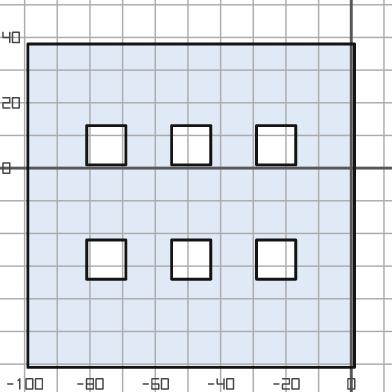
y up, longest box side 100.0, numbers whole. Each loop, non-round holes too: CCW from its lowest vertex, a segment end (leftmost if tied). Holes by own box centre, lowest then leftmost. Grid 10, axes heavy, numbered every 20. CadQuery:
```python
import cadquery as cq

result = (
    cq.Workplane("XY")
    .moveTo(-99.0, -61.0)
    .lineTo(1.0, -61.0)
    .lineTo(1.0, 38.0)
    .lineTo(-99.0, 38.0)
    .close()
    .moveTo(-81.0, -34.0)
    .lineTo(-69.0, -34.0)
    .lineTo(-69.0, -22.0)
    .lineTo(-81.0, -22.0)
    .close()
    .moveTo(-55.0, -34.0)
    .lineTo(-43.0, -34.0)
    .lineTo(-43.0, -22.0)
    .lineTo(-55.0, -22.0)
    .close()
    .moveTo(-29.0, -34.0)
    .lineTo(-17.0, -34.0)
    .lineTo(-17.0, -22.0)
    .lineTo(-29.0, -22.0)
    .close()
    .moveTo(-81.0, 1.0)
    .lineTo(-69.0, 1.0)
    .lineTo(-69.0, 13.0)
    .lineTo(-81.0, 13.0)
    .close()
    .moveTo(-55.0, 1.0)
    .lineTo(-43.0, 1.0)
    .lineTo(-43.0, 13.0)
    .lineTo(-55.0, 13.0)
    .close()
    .moveTo(-29.0, 1.0)
    .lineTo(-17.0, 1.0)
    .lineTo(-17.0, 13.0)
    .lineTo(-29.0, 13.0)
    .close()
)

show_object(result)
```